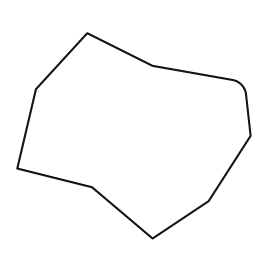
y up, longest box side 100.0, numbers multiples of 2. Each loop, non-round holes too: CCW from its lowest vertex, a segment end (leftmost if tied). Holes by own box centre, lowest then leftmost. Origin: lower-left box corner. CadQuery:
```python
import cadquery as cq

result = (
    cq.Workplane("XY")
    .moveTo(58.0, 0.0)
    .lineTo(82.0, 16.0)
    .lineTo(100.0, 44.0)
    .lineTo(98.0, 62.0)
    .threePointArc((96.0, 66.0), (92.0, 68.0))
    .lineTo(58.0, 74.0)
    .lineTo(30.0, 88.0)
    .lineTo(8.0, 64.0)
    .lineTo(0.0, 30.0)
    .lineTo(32.0, 22.0)
    .close()
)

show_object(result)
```